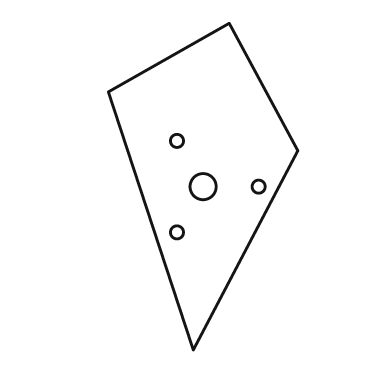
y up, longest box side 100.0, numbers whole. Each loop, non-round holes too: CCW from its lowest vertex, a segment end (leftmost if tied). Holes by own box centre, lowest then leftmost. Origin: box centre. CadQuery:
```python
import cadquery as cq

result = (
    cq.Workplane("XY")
    .moveTo(-3.0, -50.0)
    .lineTo(29.0, 11.0)
    .lineTo(8.0, 50.0)
    .lineTo(-29.0, 29.0)
    .close()
    .moveTo(-8.0, -14.0)
    .circle(2.0)
    .moveTo(0.0, 0.0)
    .circle(4.0)
    .moveTo(17.0, 0.0)
    .circle(2.0)
    .moveTo(-8.0, 14.0)
    .circle(2.0)
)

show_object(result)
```